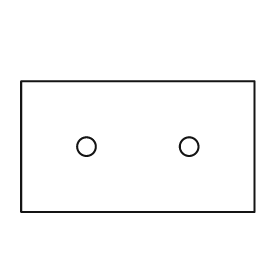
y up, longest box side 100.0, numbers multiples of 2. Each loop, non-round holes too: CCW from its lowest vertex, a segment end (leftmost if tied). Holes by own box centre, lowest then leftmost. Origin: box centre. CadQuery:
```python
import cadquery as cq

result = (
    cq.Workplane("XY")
    .moveTo(-50.0, -28.0)
    .lineTo(50.0, -28.0)
    .lineTo(50.0, 28.0)
    .lineTo(-50.0, 28.0)
    .close()
    .moveTo(-22.0, 0.0)
    .circle(4.0)
    .moveTo(22.0, 0.0)
    .circle(4.0)
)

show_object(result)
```